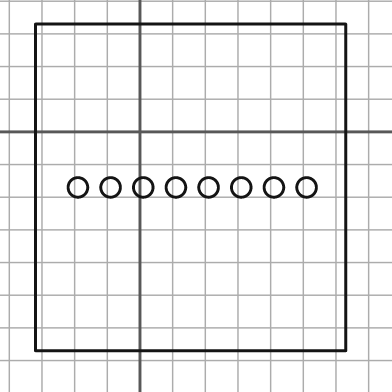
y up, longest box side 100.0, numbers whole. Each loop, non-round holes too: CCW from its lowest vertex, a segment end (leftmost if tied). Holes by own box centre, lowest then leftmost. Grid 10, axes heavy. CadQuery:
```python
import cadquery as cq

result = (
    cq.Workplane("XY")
    .moveTo(-32.0, -67.0)
    .lineTo(63.0, -67.0)
    .lineTo(63.0, 33.0)
    .lineTo(-32.0, 33.0)
    .close()
    .moveTo(-19.0, -17.0)
    .circle(3.0)
    .moveTo(-9.0, -17.0)
    .circle(3.0)
    .moveTo(1.0, -17.0)
    .circle(3.0)
    .moveTo(11.0, -17.0)
    .circle(3.0)
    .moveTo(21.0, -17.0)
    .circle(3.0)
    .moveTo(31.0, -17.0)
    .circle(3.0)
    .moveTo(41.0, -17.0)
    .circle(3.0)
    .moveTo(51.0, -17.0)
    .circle(3.0)
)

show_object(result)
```